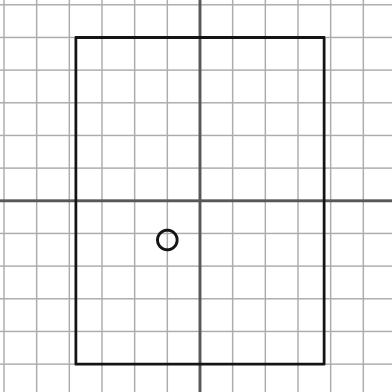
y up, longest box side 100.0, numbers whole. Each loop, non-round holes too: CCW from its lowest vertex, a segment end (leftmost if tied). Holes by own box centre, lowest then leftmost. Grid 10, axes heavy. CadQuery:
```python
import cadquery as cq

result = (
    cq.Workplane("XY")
    .moveTo(-38.0, -50.0)
    .lineTo(38.0, -50.0)
    .lineTo(38.0, 50.0)
    .lineTo(-38.0, 50.0)
    .close()
    .moveTo(-10.0, -12.0)
    .circle(3.0)
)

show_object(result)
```